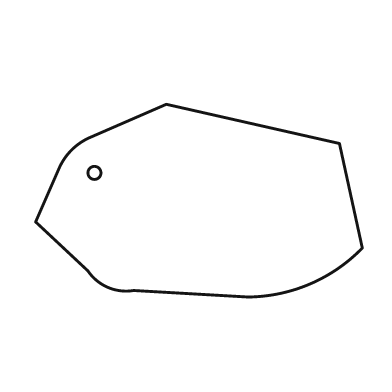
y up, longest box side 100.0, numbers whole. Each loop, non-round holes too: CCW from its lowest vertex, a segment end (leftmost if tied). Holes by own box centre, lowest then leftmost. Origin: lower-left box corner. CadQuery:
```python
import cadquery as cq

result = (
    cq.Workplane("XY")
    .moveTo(65.0, 0.0)
    .threePointArc((84.0, 4.0), (100.0, 15.0))
    .lineTo(93.0, 47.0)
    .lineTo(40.0, 59.0)
    .lineTo(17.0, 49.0)
    .threePointArc((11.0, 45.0), (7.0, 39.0))
    .lineTo(0.0, 23.0)
    .lineTo(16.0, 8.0)
    .threePointArc((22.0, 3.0), (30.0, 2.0))
    .close()
    .moveTo(18.0, 38.0)
    .circle(2.0)
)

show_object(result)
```